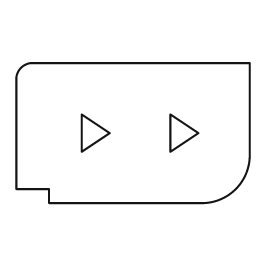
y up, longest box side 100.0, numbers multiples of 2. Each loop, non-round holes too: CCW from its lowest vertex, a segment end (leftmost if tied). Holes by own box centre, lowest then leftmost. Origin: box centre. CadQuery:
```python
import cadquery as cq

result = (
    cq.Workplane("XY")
    .moveTo(-36.0, -30.0)
    .lineTo(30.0, -30.0)
    .threePointArc((44.0, -24.0), (50.0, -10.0))
    .lineTo(50.0, 30.0)
    .lineTo(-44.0, 30.0)
    .threePointArc((-48.0, 28.0), (-50.0, 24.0))
    .lineTo(-50.0, -24.0)
    .lineTo(-36.0, -24.0)
    .close()
    .moveTo(-22.0, -8.0)
    .lineTo(-10.0, 0.0)
    .lineTo(-22.0, 8.0)
    .close()
    .moveTo(16.0, -8.0)
    .lineTo(28.0, 0.0)
    .lineTo(16.0, 8.0)
    .close()
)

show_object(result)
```